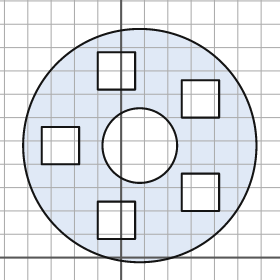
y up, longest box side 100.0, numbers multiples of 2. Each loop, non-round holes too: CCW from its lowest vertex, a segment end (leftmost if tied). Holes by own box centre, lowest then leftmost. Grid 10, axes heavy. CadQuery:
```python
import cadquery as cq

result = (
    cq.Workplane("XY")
    .moveTo(8.0, 48.0)
    .circle(50.0)
    .moveTo(-10.0, 8.0)
    .lineTo(6.0, 8.0)
    .lineTo(6.0, 24.0)
    .lineTo(-10.0, 24.0)
    .close()
    .moveTo(26.0, 20.0)
    .lineTo(42.0, 20.0)
    .lineTo(42.0, 36.0)
    .lineTo(26.0, 36.0)
    .close()
    .moveTo(-34.0, 40.0)
    .lineTo(-18.0, 40.0)
    .lineTo(-18.0, 56.0)
    .lineTo(-34.0, 56.0)
    .close()
    .moveTo(8.0, 48.0)
    .circle(16.0)
    .moveTo(26.0, 60.0)
    .lineTo(42.0, 60.0)
    .lineTo(42.0, 76.0)
    .lineTo(26.0, 76.0)
    .close()
    .moveTo(-10.0, 72.0)
    .lineTo(6.0, 72.0)
    .lineTo(6.0, 88.0)
    .lineTo(-10.0, 88.0)
    .close()
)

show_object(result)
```